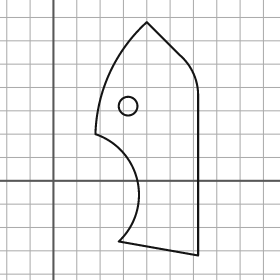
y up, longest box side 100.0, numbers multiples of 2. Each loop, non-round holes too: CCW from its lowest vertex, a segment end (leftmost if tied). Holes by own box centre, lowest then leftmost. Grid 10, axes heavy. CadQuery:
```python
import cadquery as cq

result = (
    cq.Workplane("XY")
    .moveTo(62.0, -32.0)
    .lineTo(62.0, 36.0)
    .threePointArc((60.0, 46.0), (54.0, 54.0))
    .lineTo(40.0, 68.0)
    .threePointArc((24.0, 46.0), (18.0, 20.0))
    .threePointArc((36.0, 0.0), (28.0, -26.0))
    .close()
    .moveTo(32.0, 32.0)
    .circle(4.0)
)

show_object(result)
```